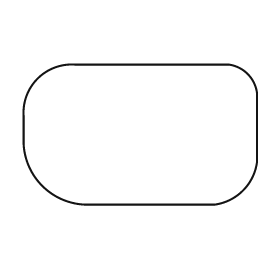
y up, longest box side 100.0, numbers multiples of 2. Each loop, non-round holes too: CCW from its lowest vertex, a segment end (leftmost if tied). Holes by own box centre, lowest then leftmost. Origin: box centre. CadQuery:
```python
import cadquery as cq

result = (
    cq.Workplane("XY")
    .moveTo(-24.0, -30.0)
    .lineTo(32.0, -30.0)
    .threePointArc((44.0, -24.0), (50.0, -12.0))
    .lineTo(50.0, 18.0)
    .threePointArc((46.0, 26.0), (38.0, 30.0))
    .lineTo(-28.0, 30.0)
    .threePointArc((-44.0, 24.0), (-50.0, 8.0))
    .lineTo(-50.0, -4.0)
    .threePointArc((-42.0, -22.0), (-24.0, -30.0))
    .close()
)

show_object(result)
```